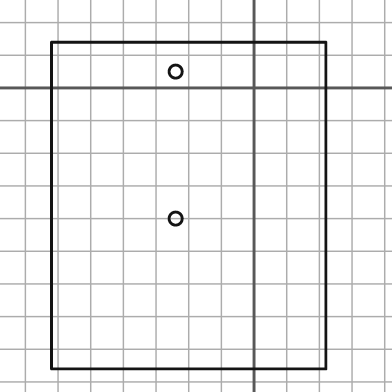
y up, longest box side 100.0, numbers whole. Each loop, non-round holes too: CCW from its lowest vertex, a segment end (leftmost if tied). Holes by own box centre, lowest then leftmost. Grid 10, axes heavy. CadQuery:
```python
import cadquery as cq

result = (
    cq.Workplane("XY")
    .moveTo(-62.0, -86.0)
    .lineTo(22.0, -86.0)
    .lineTo(22.0, 14.0)
    .lineTo(-62.0, 14.0)
    .close()
    .moveTo(-24.0, -40.0)
    .circle(2.0)
    .moveTo(-24.0, 5.0)
    .circle(2.0)
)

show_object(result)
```